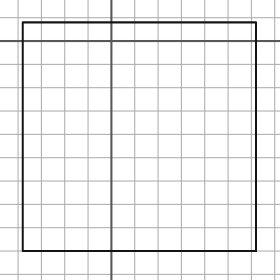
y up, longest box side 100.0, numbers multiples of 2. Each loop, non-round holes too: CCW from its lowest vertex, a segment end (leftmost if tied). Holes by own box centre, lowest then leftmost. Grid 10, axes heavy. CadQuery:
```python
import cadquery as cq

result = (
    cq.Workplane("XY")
    .moveTo(-38.0, -90.0)
    .lineTo(62.0, -90.0)
    .lineTo(62.0, 8.0)
    .lineTo(-38.0, 8.0)
    .close()
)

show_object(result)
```